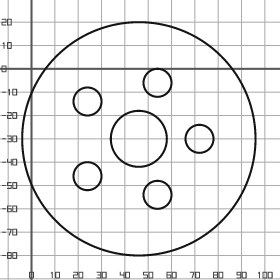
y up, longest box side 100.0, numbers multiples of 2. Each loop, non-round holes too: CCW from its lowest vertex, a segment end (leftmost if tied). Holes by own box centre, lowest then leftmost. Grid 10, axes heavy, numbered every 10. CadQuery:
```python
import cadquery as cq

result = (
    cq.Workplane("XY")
    .moveTo(46.0, -30.0)
    .circle(50.0)
    .moveTo(54.0, -54.0)
    .circle(6.0)
    .moveTo(24.0, -46.0)
    .circle(6.0)
    .moveTo(46.0, -30.0)
    .circle(12.0)
    .moveTo(72.0, -30.0)
    .circle(6.0)
    .moveTo(24.0, -14.0)
    .circle(6.0)
    .moveTo(54.0, -6.0)
    .circle(6.0)
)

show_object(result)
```